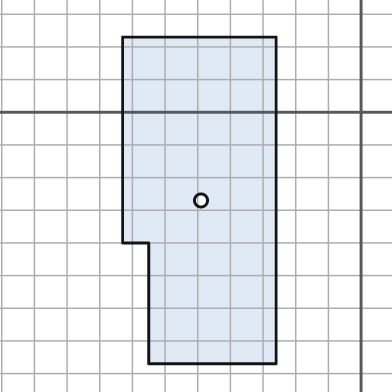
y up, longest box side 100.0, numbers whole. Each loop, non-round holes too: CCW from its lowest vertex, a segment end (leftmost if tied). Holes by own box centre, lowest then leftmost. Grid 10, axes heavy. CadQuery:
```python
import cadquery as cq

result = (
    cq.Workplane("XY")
    .moveTo(-65.0, -77.0)
    .lineTo(-26.0, -77.0)
    .lineTo(-26.0, 23.0)
    .lineTo(-73.0, 23.0)
    .lineTo(-73.0, -40.0)
    .lineTo(-65.0, -40.0)
    .close()
    .moveTo(-49.0, -27.0)
    .circle(2.0)
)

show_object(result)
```